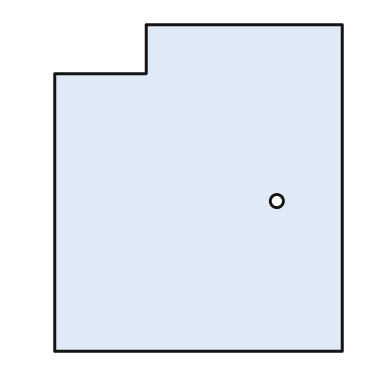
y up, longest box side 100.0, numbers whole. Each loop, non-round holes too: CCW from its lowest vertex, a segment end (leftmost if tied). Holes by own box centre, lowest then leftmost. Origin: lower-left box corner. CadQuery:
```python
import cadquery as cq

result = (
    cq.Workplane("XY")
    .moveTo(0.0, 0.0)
    .lineTo(88.0, 0.0)
    .lineTo(88.0, 100.0)
    .lineTo(28.0, 100.0)
    .lineTo(28.0, 85.0)
    .lineTo(0.0, 85.0)
    .close()
    .moveTo(68.0, 46.0)
    .circle(2.0)
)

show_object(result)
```